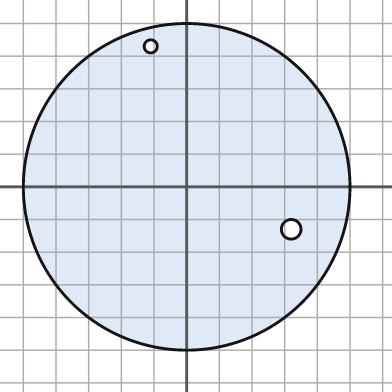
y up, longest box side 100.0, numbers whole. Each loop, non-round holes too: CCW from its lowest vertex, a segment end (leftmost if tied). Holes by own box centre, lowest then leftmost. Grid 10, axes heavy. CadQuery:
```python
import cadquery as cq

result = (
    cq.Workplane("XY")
    .moveTo(0.0, 0.0)
    .circle(50.0)
    .moveTo(32.0, -13.0)
    .circle(3.0)
    .moveTo(-11.0, 43.0)
    .circle(2.0)
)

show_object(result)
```